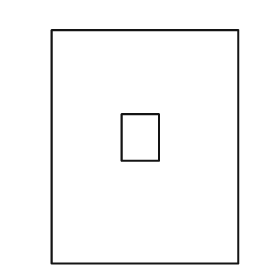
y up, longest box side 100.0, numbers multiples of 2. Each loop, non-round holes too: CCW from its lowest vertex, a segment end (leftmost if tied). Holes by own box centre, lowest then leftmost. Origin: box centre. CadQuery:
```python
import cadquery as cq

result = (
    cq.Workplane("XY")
    .moveTo(-40.0, -50.0)
    .lineTo(40.0, -50.0)
    .lineTo(40.0, 50.0)
    .lineTo(-40.0, 50.0)
    .close()
    .moveTo(-10.0, -6.0)
    .lineTo(6.0, -6.0)
    .lineTo(6.0, 14.0)
    .lineTo(-10.0, 14.0)
    .close()
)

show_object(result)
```